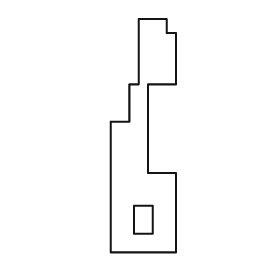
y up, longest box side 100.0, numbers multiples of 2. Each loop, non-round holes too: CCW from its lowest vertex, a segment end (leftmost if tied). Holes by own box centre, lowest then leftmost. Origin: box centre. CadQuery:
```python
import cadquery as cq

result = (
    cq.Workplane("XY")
    .moveTo(-14.0, -50.0)
    .lineTo(14.0, -50.0)
    .lineTo(14.0, -16.0)
    .lineTo(2.0, -16.0)
    .lineTo(2.0, 22.0)
    .lineTo(14.0, 22.0)
    .lineTo(14.0, 44.0)
    .lineTo(10.0, 44.0)
    .lineTo(10.0, 50.0)
    .lineTo(-2.0, 50.0)
    .lineTo(-2.0, 22.0)
    .lineTo(-6.0, 22.0)
    .lineTo(-6.0, 6.0)
    .lineTo(-14.0, 6.0)
    .close()
    .moveTo(-4.0, -42.0)
    .lineTo(4.0, -42.0)
    .lineTo(4.0, -30.0)
    .lineTo(-4.0, -30.0)
    .close()
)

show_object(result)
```